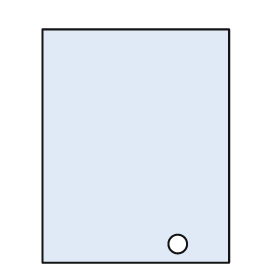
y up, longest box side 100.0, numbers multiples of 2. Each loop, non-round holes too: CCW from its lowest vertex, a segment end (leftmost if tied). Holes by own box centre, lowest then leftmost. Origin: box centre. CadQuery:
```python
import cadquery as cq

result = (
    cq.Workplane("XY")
    .moveTo(-40.0, -50.0)
    .lineTo(40.0, -50.0)
    .lineTo(40.0, 50.0)
    .lineTo(-40.0, 50.0)
    .close()
    .moveTo(18.0, -42.0)
    .circle(4.0)
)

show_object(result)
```